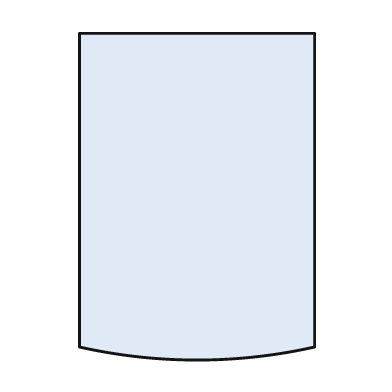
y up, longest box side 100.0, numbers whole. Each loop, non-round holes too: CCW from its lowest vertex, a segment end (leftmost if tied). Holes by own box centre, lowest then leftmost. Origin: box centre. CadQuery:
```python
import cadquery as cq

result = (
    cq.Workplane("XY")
    .moveTo(-36.0, -46.0)
    .threePointArc((0.0, -50.0), (36.0, -46.0))
    .lineTo(36.0, 50.0)
    .lineTo(-36.0, 50.0)
    .close()
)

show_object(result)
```